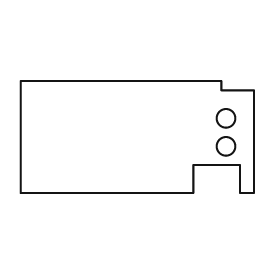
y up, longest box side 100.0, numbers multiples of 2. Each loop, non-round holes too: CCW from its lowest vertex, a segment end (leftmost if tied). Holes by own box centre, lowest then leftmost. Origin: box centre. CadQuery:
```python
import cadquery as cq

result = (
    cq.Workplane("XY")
    .moveTo(-50.0, -24.0)
    .lineTo(24.0, -24.0)
    .lineTo(24.0, -12.0)
    .lineTo(44.0, -12.0)
    .lineTo(44.0, -24.0)
    .lineTo(50.0, -24.0)
    .lineTo(50.0, 20.0)
    .lineTo(36.0, 20.0)
    .lineTo(36.0, 24.0)
    .lineTo(-50.0, 24.0)
    .close()
    .moveTo(38.0, -4.0)
    .circle(4.0)
    .moveTo(38.0, 8.0)
    .circle(4.0)
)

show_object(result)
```